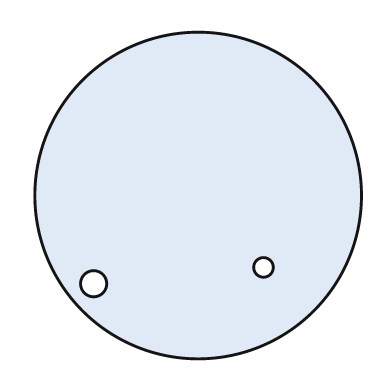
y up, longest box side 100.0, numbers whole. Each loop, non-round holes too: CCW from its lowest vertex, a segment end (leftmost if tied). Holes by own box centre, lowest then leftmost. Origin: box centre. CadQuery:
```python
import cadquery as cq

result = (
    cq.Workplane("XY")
    .moveTo(0.0, 0.0)
    .circle(50.0)
    .moveTo(-32.0, -27.0)
    .circle(4.0)
    .moveTo(20.0, -22.0)
    .circle(3.0)
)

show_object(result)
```